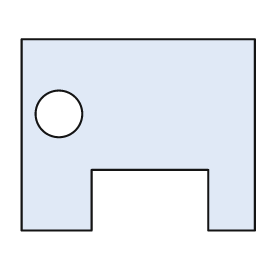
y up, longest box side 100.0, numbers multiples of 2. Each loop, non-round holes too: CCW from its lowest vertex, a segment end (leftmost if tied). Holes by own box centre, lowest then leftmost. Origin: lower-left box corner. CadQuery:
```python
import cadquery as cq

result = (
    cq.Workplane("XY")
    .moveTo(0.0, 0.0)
    .lineTo(30.0, 0.0)
    .lineTo(30.0, 26.0)
    .lineTo(80.0, 26.0)
    .lineTo(80.0, 0.0)
    .lineTo(100.0, 0.0)
    .lineTo(100.0, 82.0)
    .lineTo(0.0, 82.0)
    .close()
    .moveTo(16.0, 50.0)
    .circle(10.0)
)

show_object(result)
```